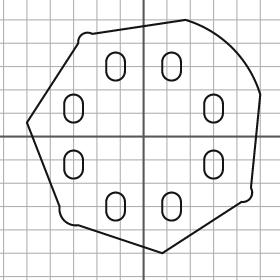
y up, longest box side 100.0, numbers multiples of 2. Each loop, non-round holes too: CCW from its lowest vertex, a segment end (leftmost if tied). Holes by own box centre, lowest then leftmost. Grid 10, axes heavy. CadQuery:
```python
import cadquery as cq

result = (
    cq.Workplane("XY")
    .moveTo(8.0, -50.0)
    .lineTo(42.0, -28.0)
    .threePointArc((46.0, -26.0), (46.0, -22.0))
    .lineTo(50.0, 18.0)
    .threePointArc((38.0, 38.0), (18.0, 50.0))
    .lineTo(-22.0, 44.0)
    .threePointArc((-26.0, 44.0), (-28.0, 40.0))
    .lineTo(-50.0, 6.0)
    .lineTo(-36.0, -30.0)
    .threePointArc((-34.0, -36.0), (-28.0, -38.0))
    .close()
    .moveTo(-16.0, -32.0)
    .threePointArc((-12.0, -36.0), (-8.0, -32.0))
    .lineTo(-8.0, -28.0)
    .threePointArc((-12.0, -24.0), (-16.0, -28.0))
    .close()
    .moveTo(8.0, -32.0)
    .threePointArc((12.0, -36.0), (16.0, -32.0))
    .lineTo(16.0, -28.0)
    .threePointArc((12.0, -24.0), (8.0, -28.0))
    .close()
    .moveTo(-34.0, -14.0)
    .threePointArc((-30.0, -18.0), (-26.0, -14.0))
    .lineTo(-26.0, -10.0)
    .threePointArc((-30.0, -6.0), (-34.0, -10.0))
    .close()
    .moveTo(26.0, -14.0)
    .threePointArc((30.0, -18.0), (34.0, -14.0))
    .lineTo(34.0, -10.0)
    .threePointArc((30.0, -6.0), (26.0, -10.0))
    .close()
    .moveTo(-34.0, 10.0)
    .threePointArc((-30.0, 6.0), (-26.0, 10.0))
    .lineTo(-26.0, 14.0)
    .threePointArc((-30.0, 18.0), (-34.0, 14.0))
    .close()
    .moveTo(26.0, 10.0)
    .threePointArc((30.0, 6.0), (34.0, 10.0))
    .lineTo(34.0, 14.0)
    .threePointArc((30.0, 18.0), (26.0, 14.0))
    .close()
    .moveTo(-16.0, 28.0)
    .threePointArc((-12.0, 24.0), (-8.0, 28.0))
    .lineTo(-8.0, 32.0)
    .threePointArc((-12.0, 36.0), (-16.0, 32.0))
    .close()
    .moveTo(8.0, 28.0)
    .threePointArc((12.0, 24.0), (16.0, 28.0))
    .lineTo(16.0, 32.0)
    .threePointArc((12.0, 36.0), (8.0, 32.0))
    .close()
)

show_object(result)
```